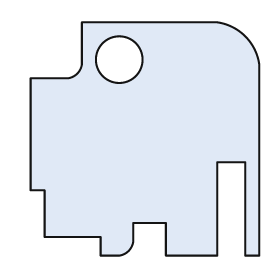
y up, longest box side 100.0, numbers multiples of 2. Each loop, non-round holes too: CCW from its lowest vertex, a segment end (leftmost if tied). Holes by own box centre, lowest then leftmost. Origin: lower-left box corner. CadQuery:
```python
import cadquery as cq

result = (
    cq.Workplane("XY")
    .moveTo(30.0, 0.0)
    .lineTo(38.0, 0.0)
    .threePointArc((42.0, 2.0), (44.0, 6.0))
    .lineTo(44.0, 14.0)
    .lineTo(58.0, 14.0)
    .lineTo(58.0, 0.0)
    .lineTo(80.0, 0.0)
    .lineTo(80.0, 40.0)
    .lineTo(92.0, 40.0)
    .lineTo(92.0, 0.0)
    .lineTo(98.0, 0.0)
    .lineTo(98.0, 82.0)
    .threePointArc((92.0, 94.0), (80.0, 100.0))
    .lineTo(22.0, 100.0)
    .lineTo(22.0, 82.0)
    .threePointArc((20.0, 78.0), (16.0, 76.0))
    .lineTo(0.0, 76.0)
    .lineTo(0.0, 28.0)
    .lineTo(6.0, 28.0)
    .lineTo(6.0, 8.0)
    .lineTo(30.0, 8.0)
    .close()
    .moveTo(38.0, 84.0)
    .circle(10.0)
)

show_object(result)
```